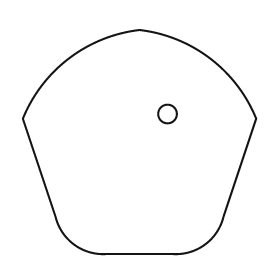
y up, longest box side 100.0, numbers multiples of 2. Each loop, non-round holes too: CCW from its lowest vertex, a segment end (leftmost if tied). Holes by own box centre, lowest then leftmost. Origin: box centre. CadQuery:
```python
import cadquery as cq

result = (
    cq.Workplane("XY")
    .moveTo(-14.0, -48.0)
    .lineTo(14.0, -48.0)
    .threePointArc((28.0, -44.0), (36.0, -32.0))
    .lineTo(50.0, 10.0)
    .threePointArc((30.0, 36.0), (0.0, 48.0))
    .threePointArc((-30.0, 36.0), (-50.0, 10.0))
    .lineTo(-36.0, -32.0)
    .threePointArc((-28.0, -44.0), (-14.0, -48.0))
    .close()
    .moveTo(12.0, 12.0)
    .circle(4.0)
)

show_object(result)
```